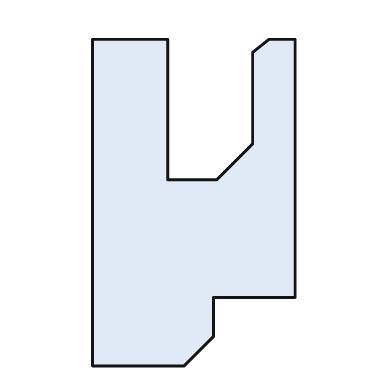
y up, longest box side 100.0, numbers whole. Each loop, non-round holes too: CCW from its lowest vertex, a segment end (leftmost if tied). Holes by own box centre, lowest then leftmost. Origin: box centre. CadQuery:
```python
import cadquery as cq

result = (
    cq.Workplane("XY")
    .moveTo(-31.0, -50.0)
    .lineTo(-3.0, -50.0)
    .lineTo(6.0, -41.0)
    .lineTo(6.0, -29.0)
    .lineTo(31.0, -29.0)
    .lineTo(31.0, 50.0)
    .lineTo(23.0, 50.0)
    .lineTo(18.0, 46.0)
    .lineTo(18.0, 18.0)
    .lineTo(7.0, 7.0)
    .lineTo(-8.0, 7.0)
    .lineTo(-8.0, 50.0)
    .lineTo(-31.0, 50.0)
    .close()
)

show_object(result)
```